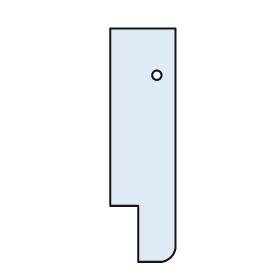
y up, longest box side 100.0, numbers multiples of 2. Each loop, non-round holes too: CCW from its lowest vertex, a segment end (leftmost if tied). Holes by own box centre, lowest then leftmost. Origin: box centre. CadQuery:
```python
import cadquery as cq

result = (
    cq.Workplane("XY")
    .moveTo(-2.0, -50.0)
    .lineTo(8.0, -50.0)
    .threePointArc((12.0, -48.0), (14.0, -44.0))
    .lineTo(14.0, 50.0)
    .lineTo(-14.0, 50.0)
    .lineTo(-14.0, -26.0)
    .lineTo(-2.0, -26.0)
    .close()
    .moveTo(6.0, 30.0)
    .circle(2.0)
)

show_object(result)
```